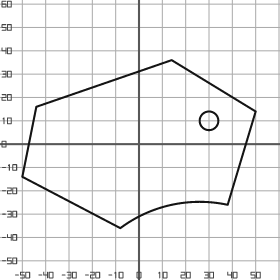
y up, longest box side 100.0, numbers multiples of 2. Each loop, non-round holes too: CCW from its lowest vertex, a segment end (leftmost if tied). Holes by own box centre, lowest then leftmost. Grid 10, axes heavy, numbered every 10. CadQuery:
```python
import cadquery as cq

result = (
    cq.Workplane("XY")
    .moveTo(-8.0, -36.0)
    .threePointArc((14.0, -26.0), (38.0, -26.0))
    .lineTo(50.0, 14.0)
    .lineTo(14.0, 36.0)
    .lineTo(-44.0, 16.0)
    .lineTo(-50.0, -14.0)
    .close()
    .moveTo(30.0, 10.0)
    .circle(4.0)
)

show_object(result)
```